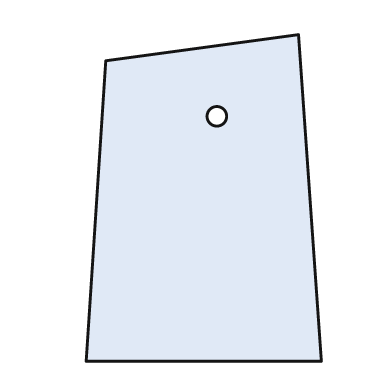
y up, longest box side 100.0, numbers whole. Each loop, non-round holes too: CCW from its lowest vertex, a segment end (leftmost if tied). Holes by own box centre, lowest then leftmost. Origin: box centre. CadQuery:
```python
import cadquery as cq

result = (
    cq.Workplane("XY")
    .moveTo(-36.0, -50.0)
    .lineTo(36.0, -50.0)
    .lineTo(29.0, 50.0)
    .lineTo(-30.0, 42.0)
    .close()
    .moveTo(4.0, 25.0)
    .circle(3.0)
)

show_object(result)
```